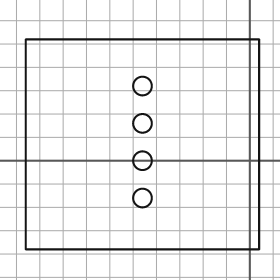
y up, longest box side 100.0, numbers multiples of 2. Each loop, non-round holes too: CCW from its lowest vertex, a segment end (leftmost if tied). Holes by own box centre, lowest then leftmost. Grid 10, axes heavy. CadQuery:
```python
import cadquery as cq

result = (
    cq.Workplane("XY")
    .moveTo(-96.0, -38.0)
    .lineTo(4.0, -38.0)
    .lineTo(4.0, 52.0)
    .lineTo(-96.0, 52.0)
    .close()
    .moveTo(-46.0, -16.0)
    .circle(4.0)
    .moveTo(-46.0, 0.0)
    .circle(4.0)
    .moveTo(-46.0, 16.0)
    .circle(4.0)
    .moveTo(-46.0, 32.0)
    .circle(4.0)
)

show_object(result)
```